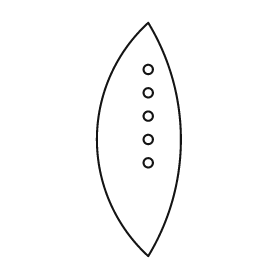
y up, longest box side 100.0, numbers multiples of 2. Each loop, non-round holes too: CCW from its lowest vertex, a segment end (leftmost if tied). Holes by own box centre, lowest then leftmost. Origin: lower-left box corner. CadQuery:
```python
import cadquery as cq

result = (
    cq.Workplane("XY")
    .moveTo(22.0, 0.0)
    .threePointArc((36.0, 50.0), (22.0, 100.0))
    .threePointArc((0.0, 50.0), (22.0, 0.0))
    .close()
    .moveTo(22.0, 40.0)
    .circle(2.0)
    .moveTo(22.0, 50.0)
    .circle(2.0)
    .moveTo(22.0, 60.0)
    .circle(2.0)
    .moveTo(22.0, 70.0)
    .circle(2.0)
    .moveTo(22.0, 80.0)
    .circle(2.0)
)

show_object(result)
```